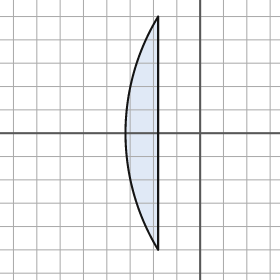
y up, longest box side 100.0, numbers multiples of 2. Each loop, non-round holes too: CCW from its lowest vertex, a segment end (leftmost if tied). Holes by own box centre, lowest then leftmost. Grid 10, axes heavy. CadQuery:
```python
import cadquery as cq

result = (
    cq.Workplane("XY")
    .moveTo(-18.0, -50.0)
    .lineTo(-18.0, 50.0)
    .threePointArc((-32.0, 0.0), (-18.0, -50.0))
    .close()
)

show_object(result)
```